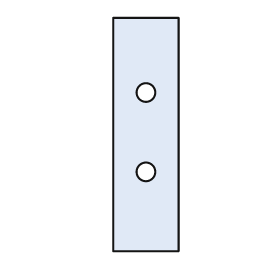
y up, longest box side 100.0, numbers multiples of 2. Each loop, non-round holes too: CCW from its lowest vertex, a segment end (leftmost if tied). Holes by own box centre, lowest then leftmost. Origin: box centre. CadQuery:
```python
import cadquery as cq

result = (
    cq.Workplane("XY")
    .moveTo(-14.0, -50.0)
    .lineTo(14.0, -50.0)
    .lineTo(14.0, 50.0)
    .lineTo(-14.0, 50.0)
    .close()
    .moveTo(0.0, -16.0)
    .circle(4.0)
    .moveTo(0.0, 18.0)
    .circle(4.0)
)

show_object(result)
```